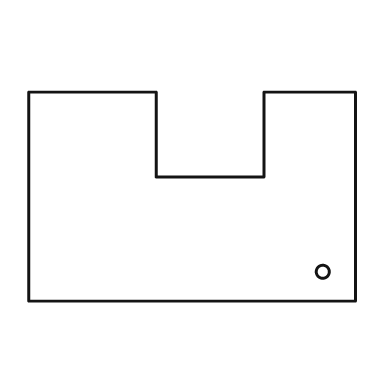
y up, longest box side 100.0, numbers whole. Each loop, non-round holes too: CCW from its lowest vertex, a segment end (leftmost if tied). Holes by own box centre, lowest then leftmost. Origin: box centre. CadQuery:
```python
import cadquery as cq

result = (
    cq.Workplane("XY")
    .moveTo(-50.0, -32.0)
    .lineTo(50.0, -32.0)
    .lineTo(50.0, 32.0)
    .lineTo(22.0, 32.0)
    .lineTo(22.0, 6.0)
    .lineTo(-11.0, 6.0)
    .lineTo(-11.0, 32.0)
    .lineTo(-50.0, 32.0)
    .close()
    .moveTo(40.0, -23.0)
    .circle(2.0)
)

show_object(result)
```